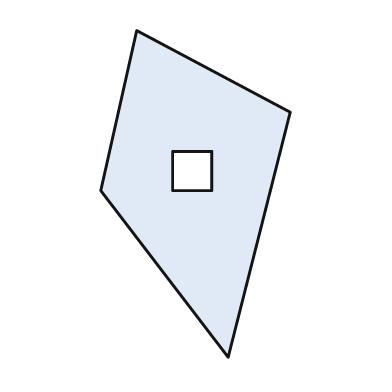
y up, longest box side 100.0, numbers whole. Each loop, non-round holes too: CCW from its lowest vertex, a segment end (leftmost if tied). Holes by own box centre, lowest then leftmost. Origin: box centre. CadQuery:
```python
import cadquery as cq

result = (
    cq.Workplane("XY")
    .moveTo(10.0, -50.0)
    .lineTo(29.0, 25.0)
    .lineTo(-18.0, 50.0)
    .lineTo(-29.0, 1.0)
    .close()
    .moveTo(-7.0, 1.0)
    .lineTo(5.0, 1.0)
    .lineTo(5.0, 13.0)
    .lineTo(-7.0, 13.0)
    .close()
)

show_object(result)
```